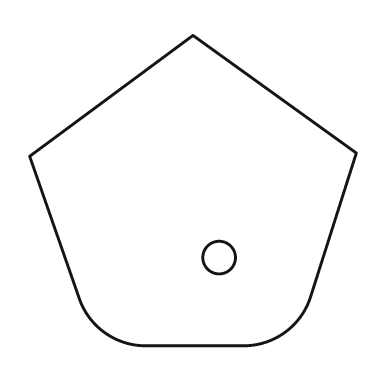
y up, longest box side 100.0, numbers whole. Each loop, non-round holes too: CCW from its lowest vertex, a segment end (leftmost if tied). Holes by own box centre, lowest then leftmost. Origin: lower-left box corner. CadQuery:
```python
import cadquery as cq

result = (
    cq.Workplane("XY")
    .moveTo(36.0, 0.0)
    .lineTo(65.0, 0.0)
    .threePointArc((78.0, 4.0), (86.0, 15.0))
    .lineTo(100.0, 59.0)
    .lineTo(50.0, 95.0)
    .lineTo(0.0, 58.0)
    .lineTo(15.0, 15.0)
    .threePointArc((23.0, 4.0), (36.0, 0.0))
    .close()
    .moveTo(58.0, 27.0)
    .circle(5.0)
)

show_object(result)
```